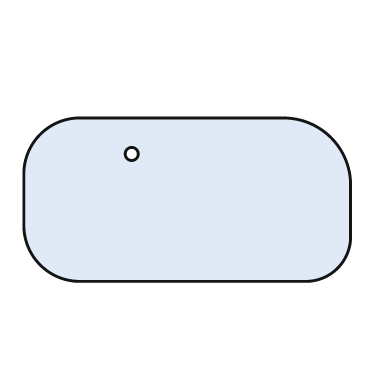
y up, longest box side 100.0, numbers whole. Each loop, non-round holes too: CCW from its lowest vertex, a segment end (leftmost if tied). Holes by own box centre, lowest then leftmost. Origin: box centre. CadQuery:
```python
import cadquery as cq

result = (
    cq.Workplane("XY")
    .moveTo(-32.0, -25.0)
    .lineTo(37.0, -25.0)
    .threePointArc((46.0, -21.0), (50.0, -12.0))
    .lineTo(50.0, 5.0)
    .threePointArc((44.0, 19.0), (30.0, 25.0))
    .lineTo(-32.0, 25.0)
    .threePointArc((-45.0, 20.0), (-50.0, 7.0))
    .lineTo(-50.0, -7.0)
    .threePointArc((-45.0, -20.0), (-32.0, -25.0))
    .close()
    .moveTo(-17.0, 14.0)
    .circle(2.0)
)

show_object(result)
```